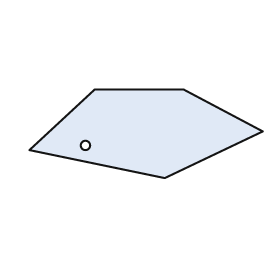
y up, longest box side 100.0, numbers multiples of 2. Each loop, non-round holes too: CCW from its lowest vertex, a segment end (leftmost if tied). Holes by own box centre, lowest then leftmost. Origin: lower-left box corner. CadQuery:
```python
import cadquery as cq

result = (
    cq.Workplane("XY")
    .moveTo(58.0, 0.0)
    .lineTo(100.0, 20.0)
    .lineTo(66.0, 38.0)
    .lineTo(28.0, 38.0)
    .lineTo(0.0, 12.0)
    .close()
    .moveTo(24.0, 14.0)
    .circle(2.0)
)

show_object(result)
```